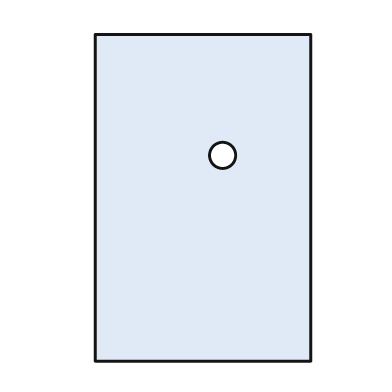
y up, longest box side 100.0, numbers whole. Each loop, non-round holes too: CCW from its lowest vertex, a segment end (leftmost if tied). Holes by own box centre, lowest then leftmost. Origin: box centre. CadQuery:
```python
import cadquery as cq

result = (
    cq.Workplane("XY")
    .moveTo(-33.0, -50.0)
    .lineTo(33.0, -50.0)
    .lineTo(33.0, 50.0)
    .lineTo(-33.0, 50.0)
    .close()
    .moveTo(6.0, 13.0)
    .circle(4.0)
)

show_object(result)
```